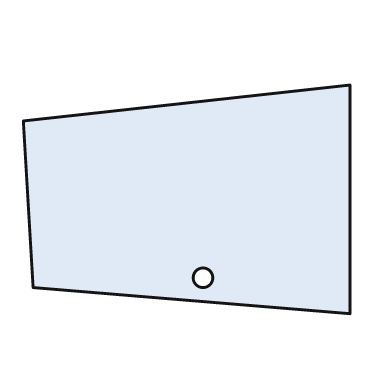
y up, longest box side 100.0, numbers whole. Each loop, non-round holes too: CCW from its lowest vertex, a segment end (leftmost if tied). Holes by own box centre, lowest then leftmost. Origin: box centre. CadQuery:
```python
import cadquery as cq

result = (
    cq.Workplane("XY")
    .moveTo(50.0, -35.0)
    .lineTo(50.0, 35.0)
    .lineTo(-50.0, 24.0)
    .lineTo(-47.0, -27.0)
    .close()
    .moveTo(5.0, -24.0)
    .circle(3.0)
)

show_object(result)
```